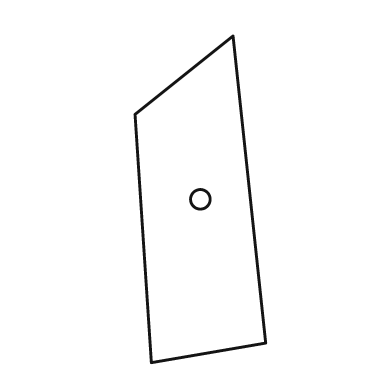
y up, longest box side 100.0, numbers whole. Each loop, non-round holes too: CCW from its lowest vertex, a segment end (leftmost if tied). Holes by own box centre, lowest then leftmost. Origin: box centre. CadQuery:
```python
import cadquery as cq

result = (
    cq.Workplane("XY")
    .moveTo(-15.0, -50.0)
    .lineTo(20.0, -44.0)
    .lineTo(10.0, 50.0)
    .lineTo(-20.0, 26.0)
    .close()
    .moveTo(0.0, 0.0)
    .circle(3.0)
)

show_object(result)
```